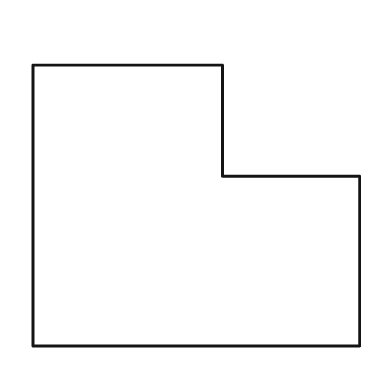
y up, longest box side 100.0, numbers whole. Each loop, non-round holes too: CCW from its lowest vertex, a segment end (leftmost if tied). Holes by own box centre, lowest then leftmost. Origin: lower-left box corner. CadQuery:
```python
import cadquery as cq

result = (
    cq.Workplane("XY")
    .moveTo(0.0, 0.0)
    .lineTo(100.0, 0.0)
    .lineTo(100.0, 52.0)
    .lineTo(58.0, 52.0)
    .lineTo(58.0, 86.0)
    .lineTo(0.0, 86.0)
    .close()
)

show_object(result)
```